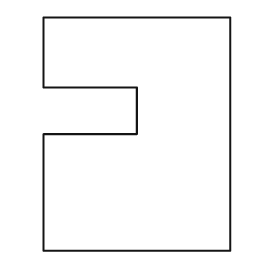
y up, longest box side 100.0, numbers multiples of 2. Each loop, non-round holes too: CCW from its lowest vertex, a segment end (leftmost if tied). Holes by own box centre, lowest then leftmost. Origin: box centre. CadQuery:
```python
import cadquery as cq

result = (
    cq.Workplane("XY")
    .moveTo(-40.0, -50.0)
    .lineTo(40.0, -50.0)
    .lineTo(40.0, 50.0)
    .lineTo(-40.0, 50.0)
    .lineTo(-40.0, 20.0)
    .lineTo(0.0, 20.0)
    .lineTo(0.0, 0.0)
    .lineTo(-40.0, 0.0)
    .close()
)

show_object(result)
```